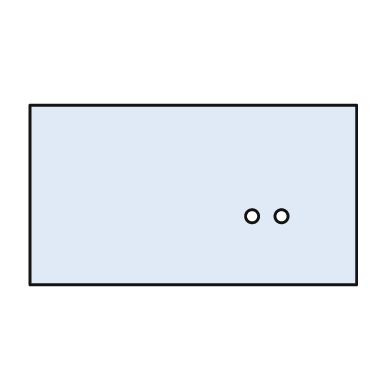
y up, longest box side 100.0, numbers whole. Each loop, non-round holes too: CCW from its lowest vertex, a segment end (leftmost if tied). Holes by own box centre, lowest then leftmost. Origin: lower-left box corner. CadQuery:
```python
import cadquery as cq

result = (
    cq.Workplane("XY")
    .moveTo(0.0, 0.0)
    .lineTo(100.0, 0.0)
    .lineTo(100.0, 55.0)
    .lineTo(0.0, 55.0)
    .close()
    .moveTo(68.0, 21.0)
    .circle(2.0)
    .moveTo(77.0, 21.0)
    .circle(2.0)
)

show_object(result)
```